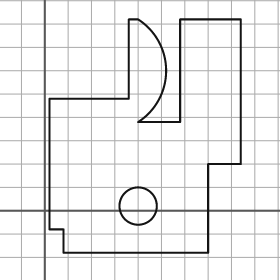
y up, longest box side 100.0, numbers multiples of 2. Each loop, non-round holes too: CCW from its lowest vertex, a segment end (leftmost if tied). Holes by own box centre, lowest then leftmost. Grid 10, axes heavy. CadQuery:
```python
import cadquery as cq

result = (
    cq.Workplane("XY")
    .moveTo(8.0, -18.0)
    .lineTo(70.0, -18.0)
    .lineTo(70.0, 20.0)
    .lineTo(84.0, 20.0)
    .lineTo(84.0, 82.0)
    .lineTo(58.0, 82.0)
    .lineTo(58.0, 38.0)
    .lineTo(40.0, 38.0)
    .threePointArc((52.0, 60.0), (40.0, 82.0))
    .lineTo(36.0, 82.0)
    .lineTo(36.0, 48.0)
    .lineTo(2.0, 48.0)
    .lineTo(2.0, -8.0)
    .lineTo(8.0, -8.0)
    .close()
    .moveTo(40.0, 2.0)
    .circle(8.0)
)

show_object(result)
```